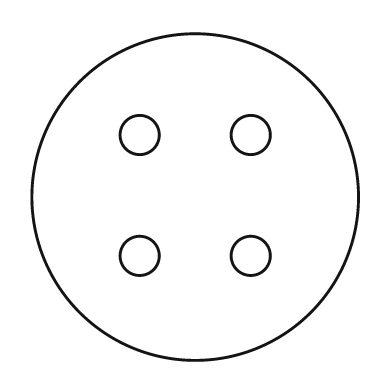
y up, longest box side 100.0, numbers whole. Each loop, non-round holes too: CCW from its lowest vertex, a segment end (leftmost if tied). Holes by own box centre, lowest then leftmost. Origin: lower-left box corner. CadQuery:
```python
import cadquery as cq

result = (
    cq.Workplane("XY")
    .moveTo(50.0, 50.0)
    .circle(50.0)
    .moveTo(33.0, 32.0)
    .circle(6.0)
    .moveTo(67.0, 32.0)
    .circle(6.0)
    .moveTo(33.0, 69.0)
    .circle(6.0)
    .moveTo(67.0, 69.0)
    .circle(6.0)
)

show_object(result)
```